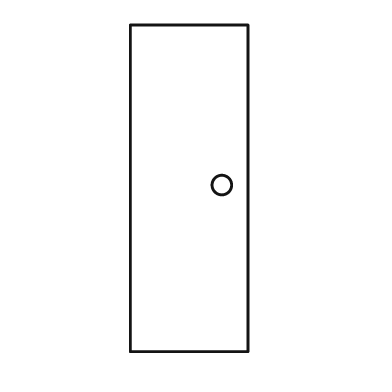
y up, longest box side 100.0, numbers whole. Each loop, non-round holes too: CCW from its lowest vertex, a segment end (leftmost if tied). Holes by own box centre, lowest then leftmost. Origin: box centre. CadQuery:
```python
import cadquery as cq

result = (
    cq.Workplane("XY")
    .moveTo(-18.0, -50.0)
    .lineTo(18.0, -50.0)
    .lineTo(18.0, 50.0)
    .lineTo(-18.0, 50.0)
    .close()
    .moveTo(10.0, 1.0)
    .circle(3.0)
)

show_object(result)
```